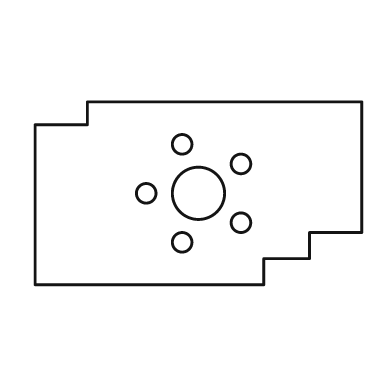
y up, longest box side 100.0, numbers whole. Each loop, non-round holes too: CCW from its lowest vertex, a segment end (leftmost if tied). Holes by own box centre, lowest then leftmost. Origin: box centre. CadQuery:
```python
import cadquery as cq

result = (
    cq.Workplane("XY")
    .moveTo(-50.0, -28.0)
    .lineTo(20.0, -28.0)
    .lineTo(20.0, -20.0)
    .lineTo(34.0, -20.0)
    .lineTo(34.0, -12.0)
    .lineTo(50.0, -12.0)
    .lineTo(50.0, 28.0)
    .lineTo(-34.0, 28.0)
    .lineTo(-34.0, 21.0)
    .lineTo(-50.0, 21.0)
    .close()
    .moveTo(-5.0, -15.0)
    .circle(3.0)
    .moveTo(13.0, -9.0)
    .circle(3.0)
    .moveTo(-16.0, 0.0)
    .circle(3.0)
    .moveTo(0.0, 0.0)
    .circle(8.0)
    .moveTo(13.0, 9.0)
    .circle(3.0)
    .moveTo(-5.0, 15.0)
    .circle(3.0)
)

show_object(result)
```